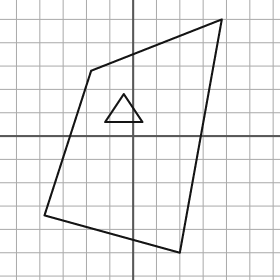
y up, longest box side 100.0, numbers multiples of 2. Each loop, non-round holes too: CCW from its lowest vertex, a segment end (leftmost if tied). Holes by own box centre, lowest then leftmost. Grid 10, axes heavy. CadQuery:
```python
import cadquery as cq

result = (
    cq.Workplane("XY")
    .moveTo(20.0, -50.0)
    .lineTo(38.0, 50.0)
    .lineTo(-18.0, 28.0)
    .lineTo(-38.0, -34.0)
    .close()
    .moveTo(-12.0, 6.0)
    .lineTo(4.0, 6.0)
    .lineTo(-4.0, 18.0)
    .close()
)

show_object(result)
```